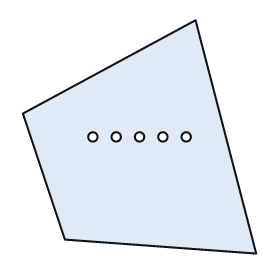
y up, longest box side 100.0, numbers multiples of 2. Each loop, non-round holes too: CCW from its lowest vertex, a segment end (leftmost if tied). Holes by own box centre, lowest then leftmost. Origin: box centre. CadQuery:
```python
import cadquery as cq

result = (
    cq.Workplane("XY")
    .moveTo(50.0, -50.0)
    .lineTo(24.0, 50.0)
    .lineTo(-50.0, 10.0)
    .lineTo(-32.0, -44.0)
    .close()
    .moveTo(-20.0, 0.0)
    .circle(2.0)
    .moveTo(-10.0, 0.0)
    .circle(2.0)
    .moveTo(0.0, 0.0)
    .circle(2.0)
    .moveTo(10.0, 0.0)
    .circle(2.0)
    .moveTo(20.0, 0.0)
    .circle(2.0)
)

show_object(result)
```